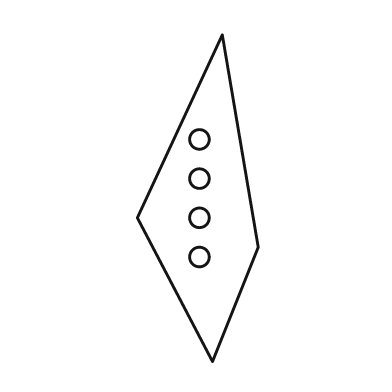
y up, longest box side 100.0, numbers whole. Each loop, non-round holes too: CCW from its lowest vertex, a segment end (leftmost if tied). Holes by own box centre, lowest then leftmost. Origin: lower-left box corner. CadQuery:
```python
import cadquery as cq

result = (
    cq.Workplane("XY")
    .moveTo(23.0, 0.0)
    .lineTo(37.0, 35.0)
    .lineTo(26.0, 100.0)
    .lineTo(0.0, 44.0)
    .close()
    .moveTo(19.0, 32.0)
    .circle(3.0)
    .moveTo(19.0, 44.0)
    .circle(3.0)
    .moveTo(19.0, 56.0)
    .circle(3.0)
    .moveTo(19.0, 68.0)
    .circle(3.0)
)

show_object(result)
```